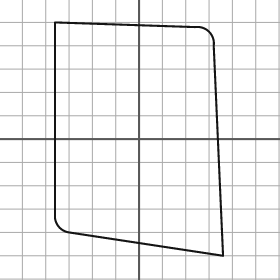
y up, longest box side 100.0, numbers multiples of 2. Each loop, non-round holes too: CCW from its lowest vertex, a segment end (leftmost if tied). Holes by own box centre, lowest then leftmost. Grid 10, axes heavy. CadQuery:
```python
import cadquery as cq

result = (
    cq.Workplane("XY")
    .moveTo(36.0, -50.0)
    .lineTo(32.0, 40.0)
    .threePointArc((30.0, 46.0), (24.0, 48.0))
    .lineTo(-36.0, 50.0)
    .lineTo(-36.0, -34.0)
    .threePointArc((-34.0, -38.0), (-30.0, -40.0))
    .close()
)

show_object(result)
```